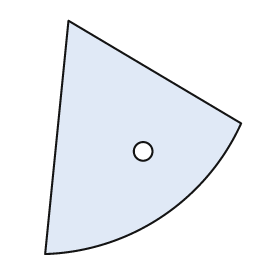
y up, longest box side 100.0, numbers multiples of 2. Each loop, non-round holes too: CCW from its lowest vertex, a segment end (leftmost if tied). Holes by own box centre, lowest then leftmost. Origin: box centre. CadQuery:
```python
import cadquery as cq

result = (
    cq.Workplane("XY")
    .moveTo(-42.0, -50.0)
    .threePointArc((8.0, -34.0), (42.0, 6.0))
    .lineTo(-32.0, 50.0)
    .close()
    .moveTo(0.0, -6.0)
    .circle(4.0)
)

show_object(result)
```